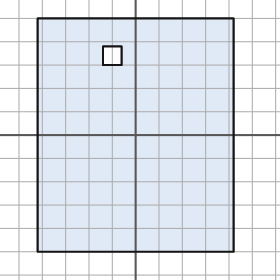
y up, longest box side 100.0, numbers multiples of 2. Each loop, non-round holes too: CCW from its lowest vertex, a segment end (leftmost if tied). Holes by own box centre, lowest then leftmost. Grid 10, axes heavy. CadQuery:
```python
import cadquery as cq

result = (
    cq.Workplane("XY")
    .moveTo(-42.0, -50.0)
    .lineTo(42.0, -50.0)
    .lineTo(42.0, 50.0)
    .lineTo(-42.0, 50.0)
    .close()
    .moveTo(-14.0, 30.0)
    .lineTo(-6.0, 30.0)
    .lineTo(-6.0, 38.0)
    .lineTo(-14.0, 38.0)
    .close()
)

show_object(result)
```